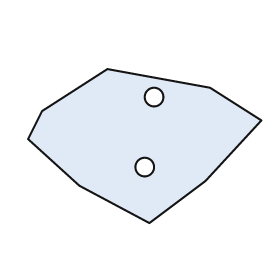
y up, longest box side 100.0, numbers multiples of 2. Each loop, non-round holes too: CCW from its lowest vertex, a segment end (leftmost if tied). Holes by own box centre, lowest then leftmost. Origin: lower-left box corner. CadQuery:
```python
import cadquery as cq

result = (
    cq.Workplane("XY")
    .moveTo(52.0, 0.0)
    .lineTo(76.0, 18.0)
    .lineTo(100.0, 44.0)
    .lineTo(78.0, 58.0)
    .lineTo(34.0, 66.0)
    .lineTo(6.0, 48.0)
    .lineTo(0.0, 36.0)
    .lineTo(22.0, 16.0)
    .close()
    .moveTo(50.0, 24.0)
    .circle(4.0)
    .moveTo(54.0, 54.0)
    .circle(4.0)
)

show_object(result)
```